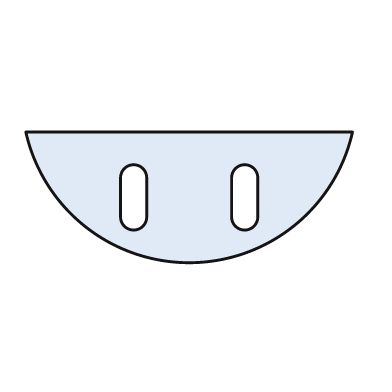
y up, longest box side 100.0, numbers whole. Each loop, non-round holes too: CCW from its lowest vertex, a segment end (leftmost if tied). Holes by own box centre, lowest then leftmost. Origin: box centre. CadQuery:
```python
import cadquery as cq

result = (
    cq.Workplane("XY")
    .moveTo(-50.0, 20.0)
    .threePointArc((0.0, -20.0), (50.0, 20.0))
    .close()
    .moveTo(-21.0, -6.0)
    .threePointArc((-17.0, -10.0), (-13.0, -6.0))
    .lineTo(-13.0, 6.0)
    .threePointArc((-17.0, 10.0), (-21.0, 6.0))
    .close()
    .moveTo(13.0, -6.0)
    .threePointArc((17.0, -10.0), (21.0, -6.0))
    .lineTo(21.0, 6.0)
    .threePointArc((17.0, 10.0), (13.0, 6.0))
    .close()
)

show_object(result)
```